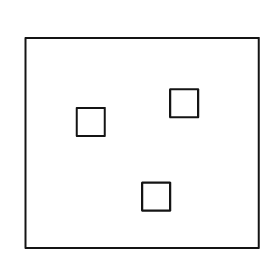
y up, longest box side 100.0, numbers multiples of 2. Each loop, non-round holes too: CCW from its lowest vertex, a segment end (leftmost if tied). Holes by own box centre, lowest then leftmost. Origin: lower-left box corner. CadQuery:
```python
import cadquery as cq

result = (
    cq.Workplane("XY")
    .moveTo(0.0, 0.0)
    .lineTo(100.0, 0.0)
    .lineTo(100.0, 90.0)
    .lineTo(0.0, 90.0)
    .close()
    .moveTo(50.0, 16.0)
    .lineTo(62.0, 16.0)
    .lineTo(62.0, 28.0)
    .lineTo(50.0, 28.0)
    .close()
    .moveTo(22.0, 48.0)
    .lineTo(34.0, 48.0)
    .lineTo(34.0, 60.0)
    .lineTo(22.0, 60.0)
    .close()
    .moveTo(62.0, 56.0)
    .lineTo(74.0, 56.0)
    .lineTo(74.0, 68.0)
    .lineTo(62.0, 68.0)
    .close()
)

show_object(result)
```